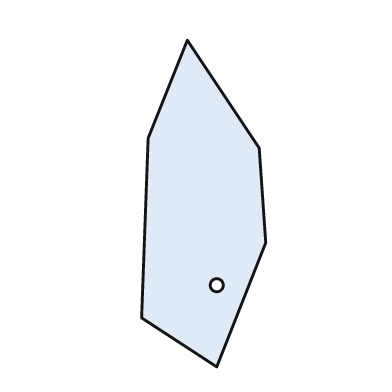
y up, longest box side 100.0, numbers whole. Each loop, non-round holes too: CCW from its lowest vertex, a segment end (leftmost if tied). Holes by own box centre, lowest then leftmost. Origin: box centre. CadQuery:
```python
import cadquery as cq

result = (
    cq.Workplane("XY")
    .moveTo(4.0, -50.0)
    .lineTo(19.0, -12.0)
    .lineTo(17.0, 17.0)
    .lineTo(-5.0, 50.0)
    .lineTo(-17.0, 20.0)
    .lineTo(-19.0, -35.0)
    .close()
    .moveTo(4.0, -25.0)
    .circle(2.0)
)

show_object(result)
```